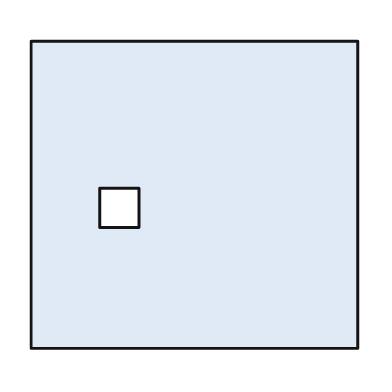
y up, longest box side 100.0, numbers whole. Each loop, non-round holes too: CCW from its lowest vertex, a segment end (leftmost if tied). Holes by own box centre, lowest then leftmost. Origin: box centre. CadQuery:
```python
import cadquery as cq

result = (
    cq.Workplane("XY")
    .moveTo(-50.0, -47.0)
    .lineTo(50.0, -47.0)
    .lineTo(50.0, 47.0)
    .lineTo(-50.0, 47.0)
    .close()
    .moveTo(-29.0, -10.0)
    .lineTo(-17.0, -10.0)
    .lineTo(-17.0, 2.0)
    .lineTo(-29.0, 2.0)
    .close()
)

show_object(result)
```